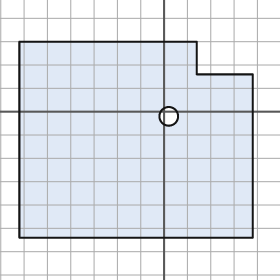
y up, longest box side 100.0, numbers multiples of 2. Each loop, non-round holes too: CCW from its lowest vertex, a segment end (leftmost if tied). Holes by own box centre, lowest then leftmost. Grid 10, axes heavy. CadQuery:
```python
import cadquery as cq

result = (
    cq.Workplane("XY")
    .moveTo(-62.0, -54.0)
    .lineTo(38.0, -54.0)
    .lineTo(38.0, 16.0)
    .lineTo(14.0, 16.0)
    .lineTo(14.0, 30.0)
    .lineTo(-62.0, 30.0)
    .close()
    .moveTo(2.0, -2.0)
    .circle(4.0)
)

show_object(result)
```